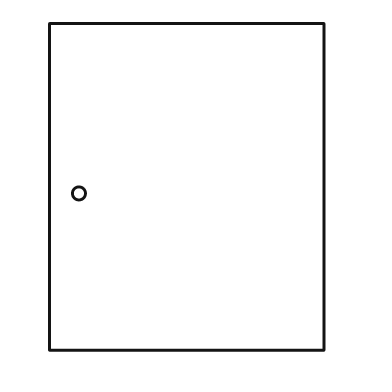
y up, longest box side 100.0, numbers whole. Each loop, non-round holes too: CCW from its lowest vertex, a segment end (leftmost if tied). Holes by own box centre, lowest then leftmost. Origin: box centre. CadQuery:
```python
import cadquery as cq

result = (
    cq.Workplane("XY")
    .moveTo(-42.0, -50.0)
    .lineTo(42.0, -50.0)
    .lineTo(42.0, 50.0)
    .lineTo(-42.0, 50.0)
    .close()
    .moveTo(-33.0, -2.0)
    .circle(2.0)
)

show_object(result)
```